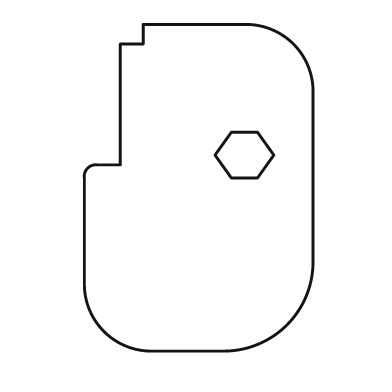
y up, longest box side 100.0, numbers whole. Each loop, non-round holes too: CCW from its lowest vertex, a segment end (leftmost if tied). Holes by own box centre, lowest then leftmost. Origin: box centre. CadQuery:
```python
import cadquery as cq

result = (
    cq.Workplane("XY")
    .moveTo(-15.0, -50.0)
    .lineTo(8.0, -50.0)
    .threePointArc((27.0, -42.0), (35.0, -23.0))
    .lineTo(35.0, 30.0)
    .threePointArc((29.0, 44.0), (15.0, 50.0))
    .lineTo(-17.0, 50.0)
    .lineTo(-17.0, 44.0)
    .lineTo(-24.0, 44.0)
    .lineTo(-24.0, 7.0)
    .lineTo(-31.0, 7.0)
    .threePointArc((-34.0, 6.0), (-35.0, 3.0))
    .lineTo(-35.0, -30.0)
    .threePointArc((-29.0, -44.0), (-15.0, -50.0))
    .close()
    .moveTo(10.0, 3.0)
    .lineTo(18.0, 3.0)
    .lineTo(23.0, 10.0)
    .lineTo(18.0, 17.0)
    .lineTo(10.0, 17.0)
    .lineTo(5.0, 10.0)
    .close()
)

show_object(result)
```